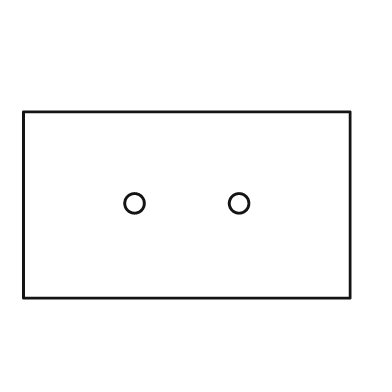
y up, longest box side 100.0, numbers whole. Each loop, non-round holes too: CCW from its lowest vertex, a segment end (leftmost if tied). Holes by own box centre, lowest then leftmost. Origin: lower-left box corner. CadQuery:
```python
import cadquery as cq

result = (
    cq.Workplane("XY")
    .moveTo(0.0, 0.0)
    .lineTo(100.0, 0.0)
    .lineTo(100.0, 57.0)
    .lineTo(0.0, 57.0)
    .close()
    .moveTo(34.0, 29.0)
    .circle(3.0)
    .moveTo(66.0, 29.0)
    .circle(3.0)
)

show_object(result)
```